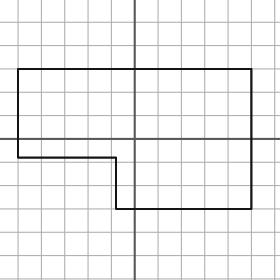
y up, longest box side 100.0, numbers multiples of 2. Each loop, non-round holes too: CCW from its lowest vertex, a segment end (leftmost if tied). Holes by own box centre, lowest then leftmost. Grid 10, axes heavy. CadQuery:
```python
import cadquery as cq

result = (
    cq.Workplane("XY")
    .moveTo(-8.0, -30.0)
    .lineTo(50.0, -30.0)
    .lineTo(50.0, 30.0)
    .lineTo(-50.0, 30.0)
    .lineTo(-50.0, -8.0)
    .lineTo(-8.0, -8.0)
    .close()
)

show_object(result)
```